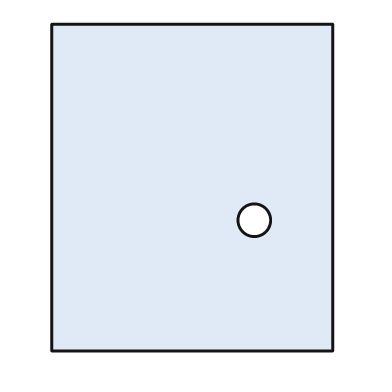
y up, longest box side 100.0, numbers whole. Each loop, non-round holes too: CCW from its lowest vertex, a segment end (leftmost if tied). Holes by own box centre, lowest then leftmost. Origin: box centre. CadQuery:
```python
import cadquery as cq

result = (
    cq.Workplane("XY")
    .moveTo(-43.0, -50.0)
    .lineTo(43.0, -50.0)
    .lineTo(43.0, 50.0)
    .lineTo(-43.0, 50.0)
    .close()
    .moveTo(19.0, -10.0)
    .circle(5.0)
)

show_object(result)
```